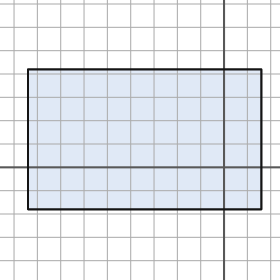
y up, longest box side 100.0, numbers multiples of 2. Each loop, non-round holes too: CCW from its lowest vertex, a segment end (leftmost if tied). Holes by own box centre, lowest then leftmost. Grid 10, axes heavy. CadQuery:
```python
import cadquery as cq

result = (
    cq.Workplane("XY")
    .moveTo(-84.0, -18.0)
    .lineTo(16.0, -18.0)
    .lineTo(16.0, 42.0)
    .lineTo(-84.0, 42.0)
    .close()
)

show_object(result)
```